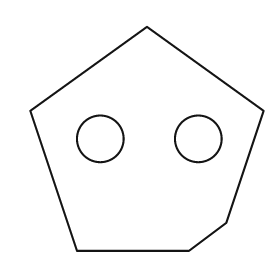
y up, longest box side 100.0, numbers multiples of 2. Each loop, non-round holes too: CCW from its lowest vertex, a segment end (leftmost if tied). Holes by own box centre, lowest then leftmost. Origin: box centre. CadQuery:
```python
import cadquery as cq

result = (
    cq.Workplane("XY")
    .moveTo(-30.0, -48.0)
    .lineTo(18.0, -48.0)
    .lineTo(34.0, -36.0)
    .lineTo(50.0, 12.0)
    .lineTo(0.0, 48.0)
    .lineTo(-50.0, 12.0)
    .close()
    .moveTo(-20.0, 0.0)
    .circle(10.0)
    .moveTo(22.0, 0.0)
    .circle(10.0)
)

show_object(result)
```